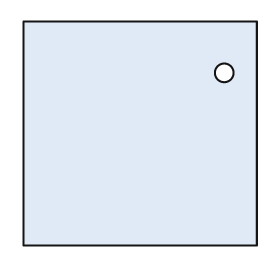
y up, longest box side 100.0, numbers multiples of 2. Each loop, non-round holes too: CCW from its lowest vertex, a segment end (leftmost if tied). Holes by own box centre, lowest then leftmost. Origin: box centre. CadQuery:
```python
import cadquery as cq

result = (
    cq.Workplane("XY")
    .moveTo(-50.0, -48.0)
    .lineTo(50.0, -48.0)
    .lineTo(50.0, 48.0)
    .lineTo(-50.0, 48.0)
    .close()
    .moveTo(36.0, 26.0)
    .circle(4.0)
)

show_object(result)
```